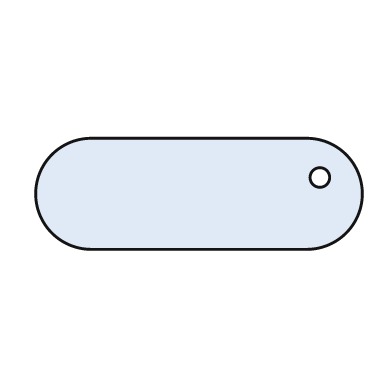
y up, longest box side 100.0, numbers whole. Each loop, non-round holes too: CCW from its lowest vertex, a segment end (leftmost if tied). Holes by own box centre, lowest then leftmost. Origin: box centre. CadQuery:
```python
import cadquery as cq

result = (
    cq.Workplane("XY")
    .moveTo(-33.0, -17.0)
    .lineTo(33.0, -17.0)
    .threePointArc((50.0, 0.0), (33.0, 17.0))
    .lineTo(-33.0, 17.0)
    .threePointArc((-50.0, 0.0), (-33.0, -17.0))
    .close()
    .moveTo(37.0, 5.0)
    .circle(3.0)
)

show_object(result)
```